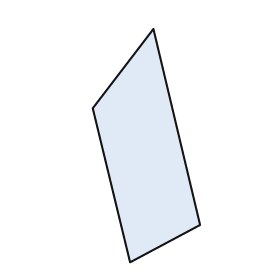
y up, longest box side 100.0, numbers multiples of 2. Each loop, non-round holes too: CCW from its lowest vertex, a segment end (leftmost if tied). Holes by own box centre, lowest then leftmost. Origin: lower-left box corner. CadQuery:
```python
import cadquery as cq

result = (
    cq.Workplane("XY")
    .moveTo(16.0, 0.0)
    .lineTo(46.0, 16.0)
    .lineTo(26.0, 100.0)
    .lineTo(0.0, 66.0)
    .close()
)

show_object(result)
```